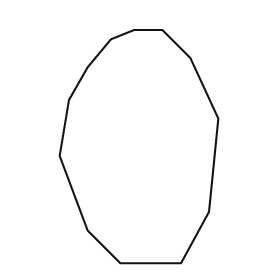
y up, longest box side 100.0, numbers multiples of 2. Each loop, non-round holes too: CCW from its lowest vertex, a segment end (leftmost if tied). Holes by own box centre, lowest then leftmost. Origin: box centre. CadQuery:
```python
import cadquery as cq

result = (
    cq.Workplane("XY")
    .moveTo(-8.0, -50.0)
    .lineTo(18.0, -50.0)
    .lineTo(30.0, -28.0)
    .lineTo(34.0, 12.0)
    .lineTo(22.0, 38.0)
    .lineTo(10.0, 50.0)
    .lineTo(-2.0, 50.0)
    .lineTo(-12.0, 46.0)
    .lineTo(-22.0, 34.0)
    .lineTo(-30.0, 20.0)
    .lineTo(-34.0, -4.0)
    .lineTo(-22.0, -36.0)
    .close()
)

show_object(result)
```